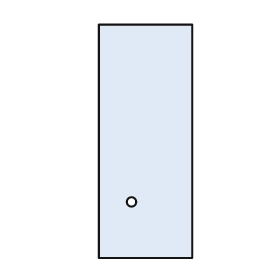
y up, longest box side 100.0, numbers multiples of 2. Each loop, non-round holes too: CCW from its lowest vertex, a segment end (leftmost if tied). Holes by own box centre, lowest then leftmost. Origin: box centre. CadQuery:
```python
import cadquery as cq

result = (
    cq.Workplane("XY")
    .moveTo(-20.0, -50.0)
    .lineTo(20.0, -50.0)
    .lineTo(20.0, 50.0)
    .lineTo(-20.0, 50.0)
    .close()
    .moveTo(-6.0, -26.0)
    .circle(2.0)
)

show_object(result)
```